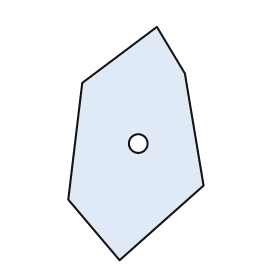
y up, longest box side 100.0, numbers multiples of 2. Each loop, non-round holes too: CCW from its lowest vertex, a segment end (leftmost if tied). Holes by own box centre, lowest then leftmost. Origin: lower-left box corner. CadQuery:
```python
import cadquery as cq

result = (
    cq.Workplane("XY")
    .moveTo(22.0, 0.0)
    .lineTo(58.0, 32.0)
    .lineTo(50.0, 80.0)
    .lineTo(38.0, 100.0)
    .lineTo(6.0, 76.0)
    .lineTo(0.0, 26.0)
    .close()
    .moveTo(30.0, 50.0)
    .circle(4.0)
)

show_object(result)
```